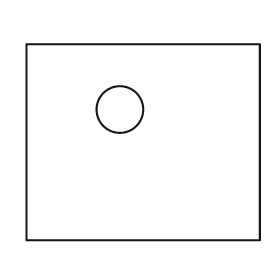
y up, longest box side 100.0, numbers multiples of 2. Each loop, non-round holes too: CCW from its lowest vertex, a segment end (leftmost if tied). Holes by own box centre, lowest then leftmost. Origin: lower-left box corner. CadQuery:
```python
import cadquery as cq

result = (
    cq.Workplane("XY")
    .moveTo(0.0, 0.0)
    .lineTo(100.0, 0.0)
    .lineTo(100.0, 84.0)
    .lineTo(0.0, 84.0)
    .close()
    .moveTo(40.0, 56.0)
    .circle(10.0)
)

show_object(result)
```